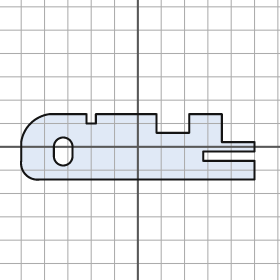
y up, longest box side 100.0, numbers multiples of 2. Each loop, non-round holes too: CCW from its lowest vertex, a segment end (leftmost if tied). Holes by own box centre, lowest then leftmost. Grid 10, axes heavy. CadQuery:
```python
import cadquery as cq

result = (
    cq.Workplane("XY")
    .moveTo(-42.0, -14.0)
    .lineTo(50.0, -14.0)
    .lineTo(50.0, -6.0)
    .lineTo(28.0, -6.0)
    .lineTo(28.0, -2.0)
    .lineTo(50.0, -2.0)
    .lineTo(50.0, 2.0)
    .lineTo(36.0, 2.0)
    .lineTo(36.0, 14.0)
    .lineTo(22.0, 14.0)
    .lineTo(22.0, 6.0)
    .lineTo(8.0, 6.0)
    .lineTo(8.0, 14.0)
    .lineTo(-18.0, 14.0)
    .lineTo(-18.0, 10.0)
    .lineTo(-22.0, 10.0)
    .lineTo(-22.0, 14.0)
    .lineTo(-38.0, 14.0)
    .threePointArc((-46.0, 10.0), (-50.0, 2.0))
    .lineTo(-50.0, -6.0)
    .threePointArc((-48.0, -12.0), (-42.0, -14.0))
    .close()
    .moveTo(-36.0, -4.0)
    .threePointArc((-32.0, -8.0), (-28.0, -4.0))
    .lineTo(-28.0, 0.0)
    .threePointArc((-32.0, 4.0), (-36.0, 0.0))
    .close()
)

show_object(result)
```